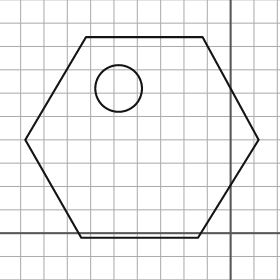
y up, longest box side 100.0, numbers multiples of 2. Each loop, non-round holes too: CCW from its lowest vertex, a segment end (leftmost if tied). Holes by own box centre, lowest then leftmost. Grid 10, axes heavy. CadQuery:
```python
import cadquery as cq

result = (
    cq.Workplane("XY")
    .moveTo(-64.0, -2.0)
    .lineTo(-14.0, -2.0)
    .lineTo(12.0, 40.0)
    .lineTo(-12.0, 84.0)
    .lineTo(-62.0, 84.0)
    .lineTo(-88.0, 40.0)
    .close()
    .moveTo(-48.0, 62.0)
    .circle(10.0)
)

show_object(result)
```